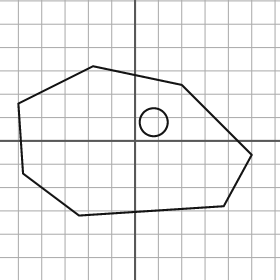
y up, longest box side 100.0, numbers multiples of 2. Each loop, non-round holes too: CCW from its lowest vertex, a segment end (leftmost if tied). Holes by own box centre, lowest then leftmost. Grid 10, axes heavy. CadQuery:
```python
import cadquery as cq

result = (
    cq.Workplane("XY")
    .moveTo(-24.0, -32.0)
    .lineTo(38.0, -28.0)
    .lineTo(50.0, -6.0)
    .lineTo(20.0, 24.0)
    .lineTo(-18.0, 32.0)
    .lineTo(-50.0, 16.0)
    .lineTo(-48.0, -14.0)
    .close()
    .moveTo(8.0, 8.0)
    .circle(6.0)
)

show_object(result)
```